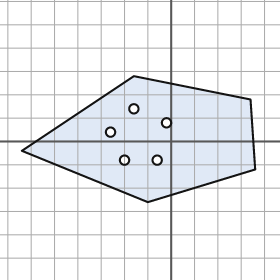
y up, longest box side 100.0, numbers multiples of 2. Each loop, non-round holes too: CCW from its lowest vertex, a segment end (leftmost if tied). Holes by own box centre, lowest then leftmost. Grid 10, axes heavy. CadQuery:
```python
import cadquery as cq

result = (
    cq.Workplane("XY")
    .moveTo(-10.0, -26.0)
    .lineTo(36.0, -12.0)
    .lineTo(34.0, 18.0)
    .lineTo(-16.0, 28.0)
    .lineTo(-64.0, -4.0)
    .close()
    .moveTo(-20.0, -8.0)
    .circle(2.0)
    .moveTo(-6.0, -8.0)
    .circle(2.0)
    .moveTo(-26.0, 4.0)
    .circle(2.0)
    .moveTo(-2.0, 8.0)
    .circle(2.0)
    .moveTo(-16.0, 14.0)
    .circle(2.0)
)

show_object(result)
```